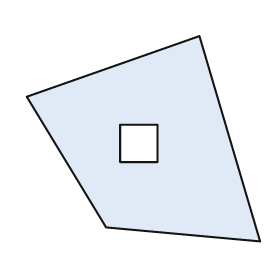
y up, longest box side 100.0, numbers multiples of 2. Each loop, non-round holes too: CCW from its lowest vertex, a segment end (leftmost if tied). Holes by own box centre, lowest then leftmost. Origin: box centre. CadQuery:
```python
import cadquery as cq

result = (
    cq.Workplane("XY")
    .moveTo(50.0, -44.0)
    .lineTo(24.0, 44.0)
    .lineTo(-50.0, 18.0)
    .lineTo(-16.0, -38.0)
    .close()
    .moveTo(-10.0, -10.0)
    .lineTo(6.0, -10.0)
    .lineTo(6.0, 6.0)
    .lineTo(-10.0, 6.0)
    .close()
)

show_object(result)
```